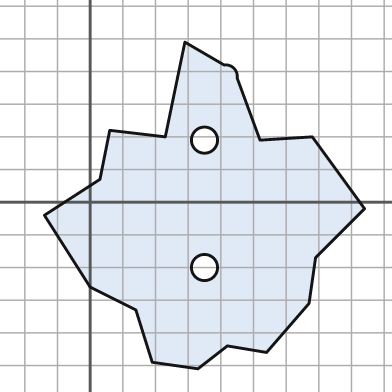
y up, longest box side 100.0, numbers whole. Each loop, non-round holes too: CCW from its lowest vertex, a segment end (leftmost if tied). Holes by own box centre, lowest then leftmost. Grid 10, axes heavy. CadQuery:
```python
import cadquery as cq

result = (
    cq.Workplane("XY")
    .moveTo(33.0, -51.0)
    .lineTo(42.0, -44.0)
    .lineTo(54.0, -46.0)
    .lineTo(67.0, -31.0)
    .lineTo(69.0, -17.0)
    .lineTo(84.0, -2.0)
    .lineTo(68.0, 20.0)
    .lineTo(52.0, 19.0)
    .lineTo(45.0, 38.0)
    .threePointArc((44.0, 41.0), (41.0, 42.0))
    .lineTo(29.0, 49.0)
    .lineTo(23.0, 20.0)
    .lineTo(6.0, 22.0)
    .lineTo(3.0, 7.0)
    .lineTo(-14.0, -4.0)
    .lineTo(0.0, -26.0)
    .lineTo(14.0, -33.0)
    .lineTo(19.0, -49.0)
    .close()
    .moveTo(35.0, -20.0)
    .circle(4.0)
    .moveTo(35.0, 19.0)
    .circle(4.0)
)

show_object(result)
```